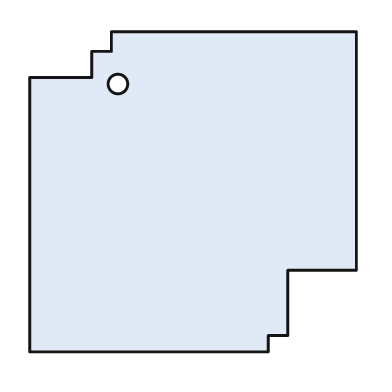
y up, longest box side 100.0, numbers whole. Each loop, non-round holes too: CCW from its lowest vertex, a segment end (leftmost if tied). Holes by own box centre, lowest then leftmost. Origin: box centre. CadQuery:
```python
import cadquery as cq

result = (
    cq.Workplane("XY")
    .moveTo(-50.0, -49.0)
    .lineTo(23.0, -49.0)
    .lineTo(23.0, -44.0)
    .lineTo(29.0, -44.0)
    .lineTo(29.0, -24.0)
    .lineTo(50.0, -24.0)
    .lineTo(50.0, 49.0)
    .lineTo(-25.0, 49.0)
    .lineTo(-25.0, 43.0)
    .lineTo(-31.0, 43.0)
    .lineTo(-31.0, 35.0)
    .lineTo(-50.0, 35.0)
    .close()
    .moveTo(-23.0, 33.0)
    .circle(3.0)
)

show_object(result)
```